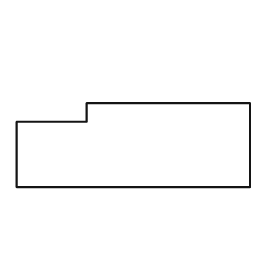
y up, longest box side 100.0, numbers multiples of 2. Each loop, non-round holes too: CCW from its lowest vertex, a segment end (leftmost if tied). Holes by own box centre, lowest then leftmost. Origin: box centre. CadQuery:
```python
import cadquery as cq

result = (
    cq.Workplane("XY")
    .moveTo(-50.0, -18.0)
    .lineTo(50.0, -18.0)
    .lineTo(50.0, 18.0)
    .lineTo(-20.0, 18.0)
    .lineTo(-20.0, 10.0)
    .lineTo(-50.0, 10.0)
    .close()
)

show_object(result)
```